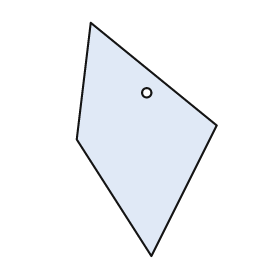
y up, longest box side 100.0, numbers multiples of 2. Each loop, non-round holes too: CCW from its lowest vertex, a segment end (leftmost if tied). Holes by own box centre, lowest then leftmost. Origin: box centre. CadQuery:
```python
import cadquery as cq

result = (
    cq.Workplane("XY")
    .moveTo(2.0, -50.0)
    .lineTo(30.0, 6.0)
    .lineTo(-24.0, 50.0)
    .lineTo(-30.0, 0.0)
    .close()
    .moveTo(0.0, 20.0)
    .circle(2.0)
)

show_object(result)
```